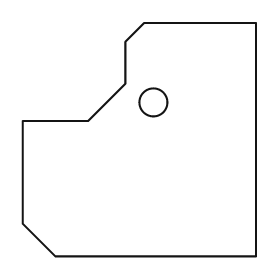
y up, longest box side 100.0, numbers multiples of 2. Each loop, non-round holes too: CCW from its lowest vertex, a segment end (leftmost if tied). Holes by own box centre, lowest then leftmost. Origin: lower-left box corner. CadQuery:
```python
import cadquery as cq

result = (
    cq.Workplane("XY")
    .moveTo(14.0, 0.0)
    .lineTo(100.0, 0.0)
    .lineTo(100.0, 100.0)
    .lineTo(52.0, 100.0)
    .lineTo(44.0, 92.0)
    .lineTo(44.0, 74.0)
    .lineTo(28.0, 58.0)
    .lineTo(0.0, 58.0)
    .lineTo(0.0, 14.0)
    .close()
    .moveTo(56.0, 66.0)
    .circle(6.0)
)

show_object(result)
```